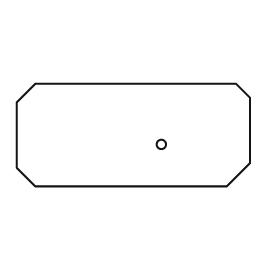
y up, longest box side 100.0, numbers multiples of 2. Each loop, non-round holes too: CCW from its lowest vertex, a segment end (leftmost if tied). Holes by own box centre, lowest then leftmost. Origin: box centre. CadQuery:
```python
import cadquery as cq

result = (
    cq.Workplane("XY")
    .moveTo(-42.0, -22.0)
    .lineTo(40.0, -22.0)
    .lineTo(50.0, -12.0)
    .lineTo(50.0, 16.0)
    .lineTo(44.0, 22.0)
    .lineTo(-42.0, 22.0)
    .lineTo(-50.0, 14.0)
    .lineTo(-50.0, -14.0)
    .close()
    .moveTo(12.0, -4.0)
    .circle(2.0)
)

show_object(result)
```